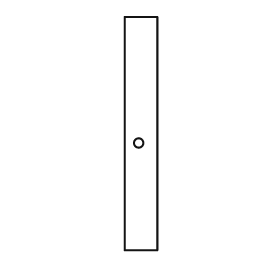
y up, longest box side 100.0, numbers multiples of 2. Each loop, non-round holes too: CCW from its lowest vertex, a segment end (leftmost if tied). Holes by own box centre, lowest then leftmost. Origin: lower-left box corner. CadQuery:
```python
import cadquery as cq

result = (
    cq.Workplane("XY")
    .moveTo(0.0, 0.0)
    .lineTo(14.0, 0.0)
    .lineTo(14.0, 100.0)
    .lineTo(0.0, 100.0)
    .close()
    .moveTo(6.0, 46.0)
    .circle(2.0)
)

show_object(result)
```